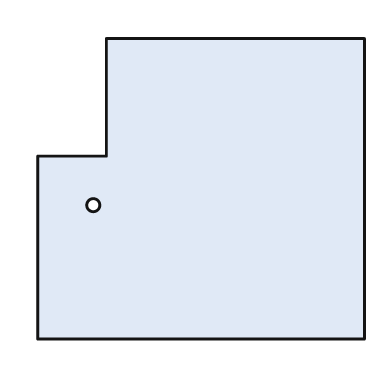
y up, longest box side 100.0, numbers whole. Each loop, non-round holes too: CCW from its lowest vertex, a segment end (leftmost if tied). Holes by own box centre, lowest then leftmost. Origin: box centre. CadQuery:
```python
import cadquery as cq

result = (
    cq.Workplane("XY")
    .moveTo(-50.0, -46.0)
    .lineTo(50.0, -46.0)
    .lineTo(50.0, 46.0)
    .lineTo(-29.0, 46.0)
    .lineTo(-29.0, 10.0)
    .lineTo(-50.0, 10.0)
    .close()
    .moveTo(-33.0, -5.0)
    .circle(2.0)
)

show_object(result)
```